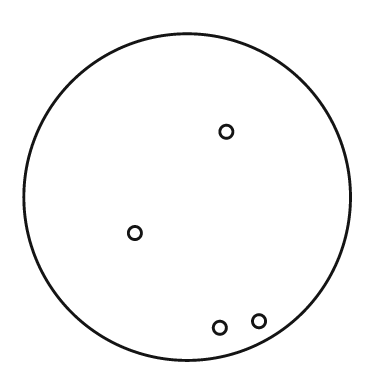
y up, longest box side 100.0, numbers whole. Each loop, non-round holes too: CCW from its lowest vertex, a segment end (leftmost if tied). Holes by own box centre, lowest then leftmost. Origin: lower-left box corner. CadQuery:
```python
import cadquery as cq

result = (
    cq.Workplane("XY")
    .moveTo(50.0, 50.0)
    .circle(50.0)
    .moveTo(60.0, 10.0)
    .circle(2.0)
    .moveTo(72.0, 12.0)
    .circle(2.0)
    .moveTo(34.0, 39.0)
    .circle(2.0)
    .moveTo(62.0, 70.0)
    .circle(2.0)
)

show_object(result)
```